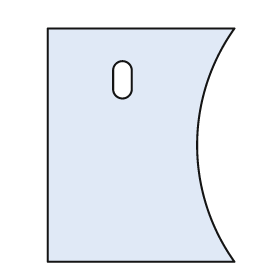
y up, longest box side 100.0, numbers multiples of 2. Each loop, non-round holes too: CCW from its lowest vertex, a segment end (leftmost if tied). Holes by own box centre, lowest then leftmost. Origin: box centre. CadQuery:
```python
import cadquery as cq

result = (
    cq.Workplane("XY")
    .moveTo(-40.0, -50.0)
    .lineTo(40.0, -50.0)
    .threePointArc((24.0, 0.0), (40.0, 50.0))
    .lineTo(-40.0, 50.0)
    .close()
    .moveTo(-12.0, 24.0)
    .threePointArc((-8.0, 20.0), (-4.0, 24.0))
    .lineTo(-4.0, 32.0)
    .threePointArc((-8.0, 36.0), (-12.0, 32.0))
    .close()
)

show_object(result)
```